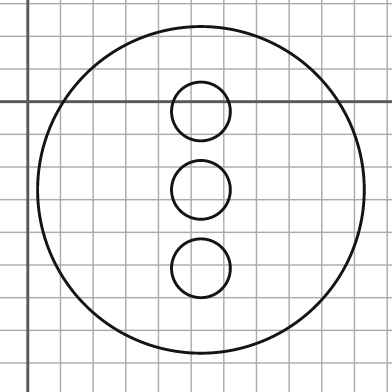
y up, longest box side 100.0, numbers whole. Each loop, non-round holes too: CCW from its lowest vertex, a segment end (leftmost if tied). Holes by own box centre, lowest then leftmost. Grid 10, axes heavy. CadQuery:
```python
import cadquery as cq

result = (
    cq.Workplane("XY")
    .moveTo(53.0, -27.0)
    .circle(50.0)
    .moveTo(53.0, -51.0)
    .circle(9.0)
    .moveTo(53.0, -27.0)
    .circle(9.0)
    .moveTo(53.0, -3.0)
    .circle(9.0)
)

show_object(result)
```